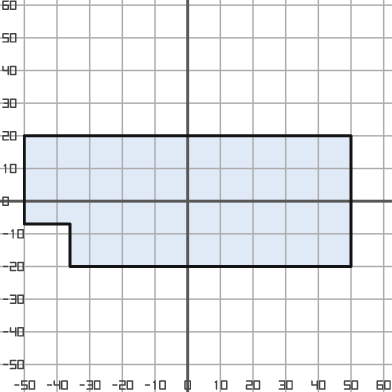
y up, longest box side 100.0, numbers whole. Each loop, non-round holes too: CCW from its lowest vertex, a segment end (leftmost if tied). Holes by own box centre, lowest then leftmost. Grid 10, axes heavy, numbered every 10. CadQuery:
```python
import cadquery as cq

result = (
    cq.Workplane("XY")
    .moveTo(-36.0, -20.0)
    .lineTo(50.0, -20.0)
    .lineTo(50.0, 20.0)
    .lineTo(-50.0, 20.0)
    .lineTo(-50.0, -7.0)
    .lineTo(-36.0, -7.0)
    .close()
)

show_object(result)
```